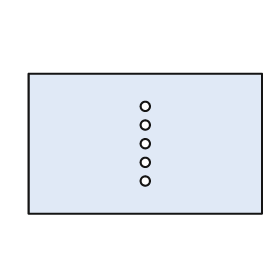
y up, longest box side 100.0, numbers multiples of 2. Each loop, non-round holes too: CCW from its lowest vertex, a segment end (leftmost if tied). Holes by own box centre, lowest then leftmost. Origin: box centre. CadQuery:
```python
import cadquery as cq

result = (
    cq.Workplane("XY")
    .moveTo(-50.0, -30.0)
    .lineTo(50.0, -30.0)
    .lineTo(50.0, 30.0)
    .lineTo(-50.0, 30.0)
    .close()
    .moveTo(0.0, -16.0)
    .circle(2.0)
    .moveTo(0.0, -8.0)
    .circle(2.0)
    .moveTo(0.0, 0.0)
    .circle(2.0)
    .moveTo(0.0, 8.0)
    .circle(2.0)
    .moveTo(0.0, 16.0)
    .circle(2.0)
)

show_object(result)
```